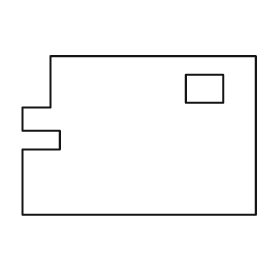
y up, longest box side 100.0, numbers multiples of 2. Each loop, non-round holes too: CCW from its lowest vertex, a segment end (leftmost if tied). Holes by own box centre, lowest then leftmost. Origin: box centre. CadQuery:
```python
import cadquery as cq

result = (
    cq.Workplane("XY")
    .moveTo(-50.0, -34.0)
    .lineTo(50.0, -34.0)
    .lineTo(50.0, 34.0)
    .lineTo(-38.0, 34.0)
    .lineTo(-38.0, 12.0)
    .lineTo(-50.0, 12.0)
    .lineTo(-50.0, 2.0)
    .lineTo(-34.0, 2.0)
    .lineTo(-34.0, -6.0)
    .lineTo(-50.0, -6.0)
    .close()
    .moveTo(20.0, 14.0)
    .lineTo(36.0, 14.0)
    .lineTo(36.0, 26.0)
    .lineTo(20.0, 26.0)
    .close()
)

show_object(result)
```